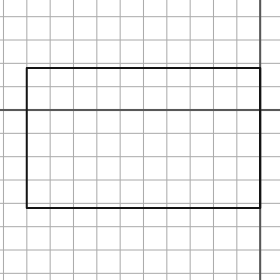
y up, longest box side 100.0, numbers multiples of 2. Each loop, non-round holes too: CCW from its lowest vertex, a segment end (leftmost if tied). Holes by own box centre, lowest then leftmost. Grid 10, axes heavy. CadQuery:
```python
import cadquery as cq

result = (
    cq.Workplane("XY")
    .moveTo(-100.0, -42.0)
    .lineTo(0.0, -42.0)
    .lineTo(0.0, 18.0)
    .lineTo(-100.0, 18.0)
    .close()
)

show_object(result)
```